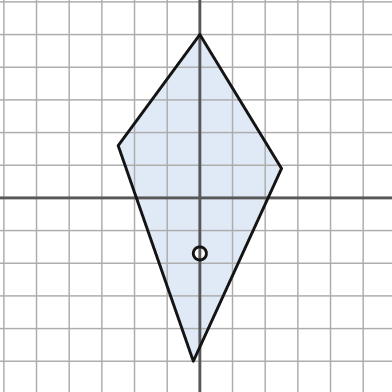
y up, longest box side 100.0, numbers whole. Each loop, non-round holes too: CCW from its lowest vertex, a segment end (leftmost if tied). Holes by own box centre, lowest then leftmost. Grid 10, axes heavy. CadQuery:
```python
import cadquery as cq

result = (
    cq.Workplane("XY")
    .moveTo(-2.0, -50.0)
    .lineTo(25.0, 9.0)
    .lineTo(0.0, 50.0)
    .lineTo(-25.0, 16.0)
    .close()
    .moveTo(0.0, -17.0)
    .circle(2.0)
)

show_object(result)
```